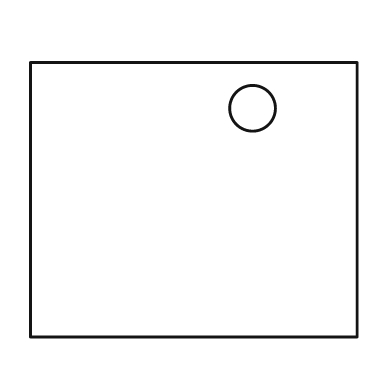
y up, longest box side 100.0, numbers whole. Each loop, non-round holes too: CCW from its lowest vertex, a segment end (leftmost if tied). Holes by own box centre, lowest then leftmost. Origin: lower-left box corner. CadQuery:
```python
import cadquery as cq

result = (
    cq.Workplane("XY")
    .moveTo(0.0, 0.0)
    .lineTo(100.0, 0.0)
    .lineTo(100.0, 84.0)
    .lineTo(0.0, 84.0)
    .close()
    .moveTo(68.0, 70.0)
    .circle(7.0)
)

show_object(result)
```